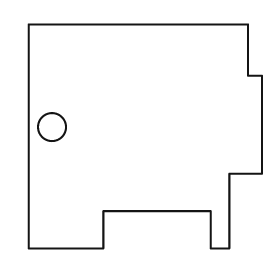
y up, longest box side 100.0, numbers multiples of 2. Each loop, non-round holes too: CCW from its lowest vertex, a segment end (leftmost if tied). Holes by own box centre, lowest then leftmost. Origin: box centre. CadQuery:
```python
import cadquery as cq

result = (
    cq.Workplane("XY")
    .moveTo(-50.0, -48.0)
    .lineTo(-18.0, -48.0)
    .lineTo(-18.0, -32.0)
    .lineTo(28.0, -32.0)
    .lineTo(28.0, -48.0)
    .lineTo(36.0, -48.0)
    .lineTo(36.0, -16.0)
    .lineTo(50.0, -16.0)
    .lineTo(50.0, 26.0)
    .lineTo(44.0, 26.0)
    .lineTo(44.0, 48.0)
    .lineTo(-50.0, 48.0)
    .close()
    .moveTo(-40.0, 4.0)
    .circle(6.0)
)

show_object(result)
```